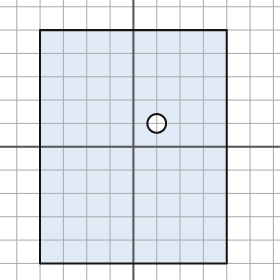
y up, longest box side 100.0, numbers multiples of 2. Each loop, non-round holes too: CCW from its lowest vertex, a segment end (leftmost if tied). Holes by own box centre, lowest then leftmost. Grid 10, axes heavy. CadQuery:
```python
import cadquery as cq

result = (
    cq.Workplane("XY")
    .moveTo(-40.0, -50.0)
    .lineTo(40.0, -50.0)
    .lineTo(40.0, 50.0)
    .lineTo(-40.0, 50.0)
    .close()
    .moveTo(10.0, 10.0)
    .circle(4.0)
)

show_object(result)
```